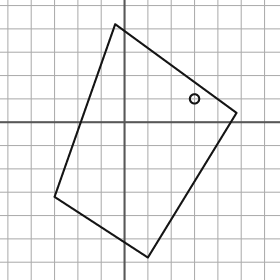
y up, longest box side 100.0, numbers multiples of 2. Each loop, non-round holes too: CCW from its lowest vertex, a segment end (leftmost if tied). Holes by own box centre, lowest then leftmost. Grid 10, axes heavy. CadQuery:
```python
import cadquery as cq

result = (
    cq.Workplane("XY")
    .moveTo(10.0, -58.0)
    .lineTo(48.0, 4.0)
    .lineTo(-4.0, 42.0)
    .lineTo(-30.0, -32.0)
    .close()
    .moveTo(30.0, 10.0)
    .circle(2.0)
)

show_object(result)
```